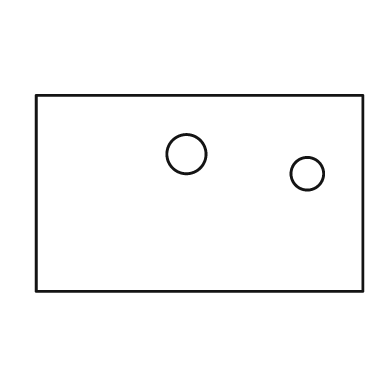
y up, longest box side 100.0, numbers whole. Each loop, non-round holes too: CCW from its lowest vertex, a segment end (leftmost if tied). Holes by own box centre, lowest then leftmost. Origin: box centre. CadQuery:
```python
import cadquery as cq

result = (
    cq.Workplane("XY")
    .moveTo(-50.0, -30.0)
    .lineTo(50.0, -30.0)
    .lineTo(50.0, 30.0)
    .lineTo(-50.0, 30.0)
    .close()
    .moveTo(33.0, 6.0)
    .circle(5.0)
    .moveTo(-4.0, 12.0)
    .circle(6.0)
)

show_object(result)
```